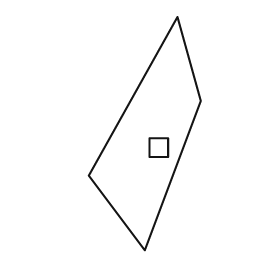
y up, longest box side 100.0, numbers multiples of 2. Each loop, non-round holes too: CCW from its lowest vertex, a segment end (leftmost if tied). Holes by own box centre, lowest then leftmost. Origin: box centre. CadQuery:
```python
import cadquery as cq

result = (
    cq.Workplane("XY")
    .moveTo(0.0, -50.0)
    .lineTo(24.0, 14.0)
    .lineTo(14.0, 50.0)
    .lineTo(-24.0, -18.0)
    .close()
    .moveTo(2.0, -10.0)
    .lineTo(10.0, -10.0)
    .lineTo(10.0, -2.0)
    .lineTo(2.0, -2.0)
    .close()
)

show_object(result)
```